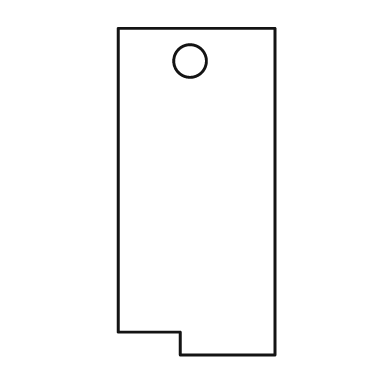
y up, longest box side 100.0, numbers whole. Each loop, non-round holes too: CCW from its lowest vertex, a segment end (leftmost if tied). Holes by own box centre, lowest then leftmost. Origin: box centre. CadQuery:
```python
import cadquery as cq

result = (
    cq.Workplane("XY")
    .moveTo(-5.0, -50.0)
    .lineTo(24.0, -50.0)
    .lineTo(24.0, 50.0)
    .lineTo(-24.0, 50.0)
    .lineTo(-24.0, -43.0)
    .lineTo(-5.0, -43.0)
    .close()
    .moveTo(-2.0, 40.0)
    .circle(5.0)
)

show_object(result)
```